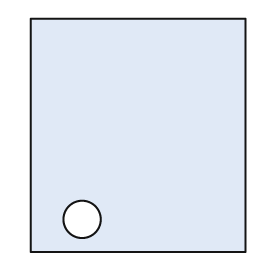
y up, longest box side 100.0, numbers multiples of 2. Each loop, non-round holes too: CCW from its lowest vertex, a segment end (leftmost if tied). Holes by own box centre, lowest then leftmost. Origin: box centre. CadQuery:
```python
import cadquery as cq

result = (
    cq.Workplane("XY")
    .moveTo(-46.0, -50.0)
    .lineTo(46.0, -50.0)
    .lineTo(46.0, 50.0)
    .lineTo(-46.0, 50.0)
    .close()
    .moveTo(-24.0, -36.0)
    .circle(8.0)
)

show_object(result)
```